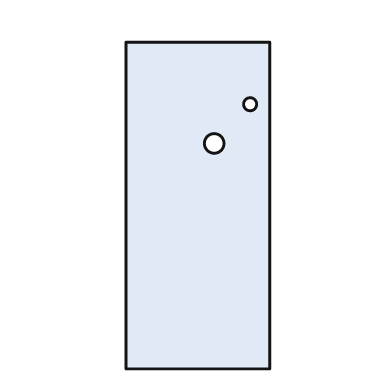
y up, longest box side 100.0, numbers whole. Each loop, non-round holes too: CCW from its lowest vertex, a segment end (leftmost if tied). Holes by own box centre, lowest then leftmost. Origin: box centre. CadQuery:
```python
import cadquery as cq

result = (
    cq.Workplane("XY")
    .moveTo(-22.0, -50.0)
    .lineTo(22.0, -50.0)
    .lineTo(22.0, 50.0)
    .lineTo(-22.0, 50.0)
    .close()
    .moveTo(5.0, 19.0)
    .circle(3.0)
    .moveTo(16.0, 31.0)
    .circle(2.0)
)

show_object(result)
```